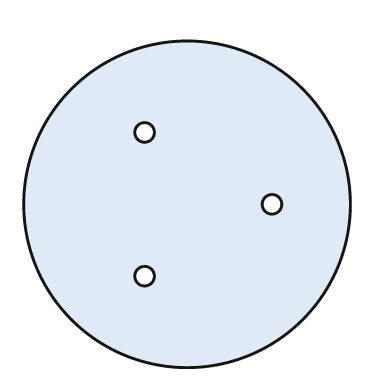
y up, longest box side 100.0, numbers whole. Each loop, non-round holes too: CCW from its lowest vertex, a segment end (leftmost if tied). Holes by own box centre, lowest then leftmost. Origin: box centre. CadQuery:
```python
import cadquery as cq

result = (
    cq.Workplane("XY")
    .moveTo(0.0, 0.0)
    .circle(50.0)
    .moveTo(-13.0, -22.0)
    .circle(3.0)
    .moveTo(26.0, 0.0)
    .circle(3.0)
    .moveTo(-13.0, 22.0)
    .circle(3.0)
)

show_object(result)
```